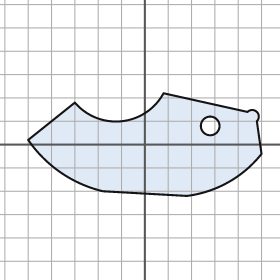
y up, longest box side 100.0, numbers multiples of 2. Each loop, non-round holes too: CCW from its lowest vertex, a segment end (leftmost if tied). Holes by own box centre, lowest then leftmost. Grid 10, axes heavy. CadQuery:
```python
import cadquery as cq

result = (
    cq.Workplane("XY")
    .moveTo(18.0, -22.0)
    .threePointArc((36.0, -16.0), (50.0, -4.0))
    .lineTo(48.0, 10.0)
    .threePointArc((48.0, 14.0), (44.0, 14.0))
    .lineTo(8.0, 22.0)
    .threePointArc((-10.0, 10.0), (-30.0, 18.0))
    .lineTo(-50.0, 2.0)
    .threePointArc((-36.0, -12.0), (-18.0, -20.0))
    .close()
    .moveTo(28.0, 8.0)
    .circle(4.0)
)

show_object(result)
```